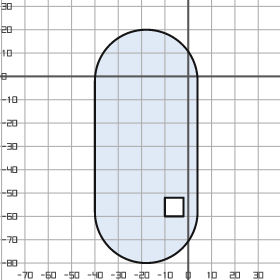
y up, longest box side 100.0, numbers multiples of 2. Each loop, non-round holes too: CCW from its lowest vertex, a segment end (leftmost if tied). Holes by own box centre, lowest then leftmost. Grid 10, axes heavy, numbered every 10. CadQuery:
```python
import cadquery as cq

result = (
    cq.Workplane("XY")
    .moveTo(-40.0, -58.0)
    .threePointArc((-18.0, -80.0), (4.0, -58.0))
    .lineTo(4.0, -2.0)
    .threePointArc((-18.0, 20.0), (-40.0, -2.0))
    .close()
    .moveTo(-10.0, -60.0)
    .lineTo(-2.0, -60.0)
    .lineTo(-2.0, -52.0)
    .lineTo(-10.0, -52.0)
    .close()
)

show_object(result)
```